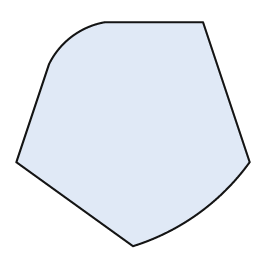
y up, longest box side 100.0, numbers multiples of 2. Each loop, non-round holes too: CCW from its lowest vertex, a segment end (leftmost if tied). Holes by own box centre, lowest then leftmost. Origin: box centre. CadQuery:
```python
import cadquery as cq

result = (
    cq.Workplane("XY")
    .moveTo(0.0, -48.0)
    .threePointArc((28.0, -34.0), (50.0, -12.0))
    .lineTo(30.0, 48.0)
    .lineTo(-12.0, 48.0)
    .threePointArc((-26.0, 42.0), (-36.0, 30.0))
    .lineTo(-50.0, -12.0)
    .close()
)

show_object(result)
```